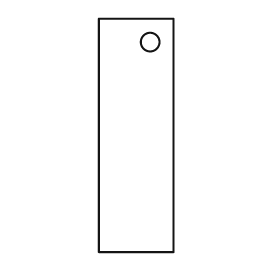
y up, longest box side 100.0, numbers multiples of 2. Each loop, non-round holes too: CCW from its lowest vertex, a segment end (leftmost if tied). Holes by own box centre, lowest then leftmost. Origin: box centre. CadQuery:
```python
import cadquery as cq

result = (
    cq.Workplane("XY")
    .moveTo(-16.0, -50.0)
    .lineTo(16.0, -50.0)
    .lineTo(16.0, 50.0)
    .lineTo(-16.0, 50.0)
    .close()
    .moveTo(6.0, 40.0)
    .circle(4.0)
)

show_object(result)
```